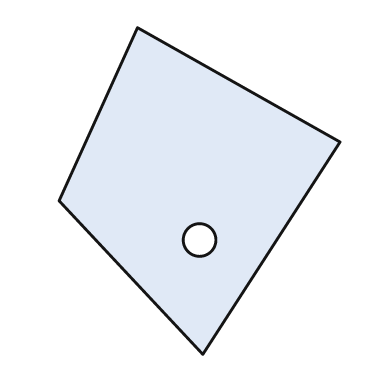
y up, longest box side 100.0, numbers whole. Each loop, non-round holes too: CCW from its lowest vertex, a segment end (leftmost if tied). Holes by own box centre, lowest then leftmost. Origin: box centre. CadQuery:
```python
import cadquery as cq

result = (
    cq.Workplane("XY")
    .moveTo(1.0, -50.0)
    .lineTo(43.0, 15.0)
    .lineTo(-19.0, 50.0)
    .lineTo(-43.0, -3.0)
    .close()
    .moveTo(0.0, -15.0)
    .circle(5.0)
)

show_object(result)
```